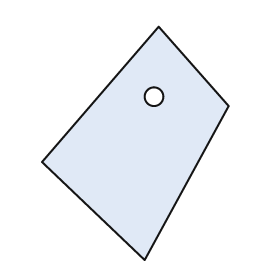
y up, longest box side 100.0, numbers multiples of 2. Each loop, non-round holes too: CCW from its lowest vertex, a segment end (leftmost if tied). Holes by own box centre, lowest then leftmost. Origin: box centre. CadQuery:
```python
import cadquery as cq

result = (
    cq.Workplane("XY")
    .moveTo(4.0, -50.0)
    .lineTo(40.0, 16.0)
    .lineTo(10.0, 50.0)
    .lineTo(-40.0, -8.0)
    .close()
    .moveTo(8.0, 20.0)
    .circle(4.0)
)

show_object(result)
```